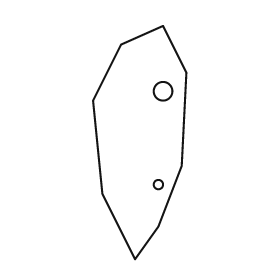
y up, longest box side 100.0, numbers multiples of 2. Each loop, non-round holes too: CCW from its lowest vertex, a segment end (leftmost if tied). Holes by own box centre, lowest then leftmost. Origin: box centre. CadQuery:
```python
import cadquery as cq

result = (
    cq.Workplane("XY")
    .moveTo(-2.0, -50.0)
    .lineTo(8.0, -36.0)
    .lineTo(18.0, -10.0)
    .lineTo(20.0, 30.0)
    .lineTo(10.0, 50.0)
    .lineTo(-8.0, 42.0)
    .lineTo(-20.0, 18.0)
    .lineTo(-16.0, -22.0)
    .close()
    .moveTo(8.0, -18.0)
    .circle(2.0)
    .moveTo(10.0, 22.0)
    .circle(4.0)
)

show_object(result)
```